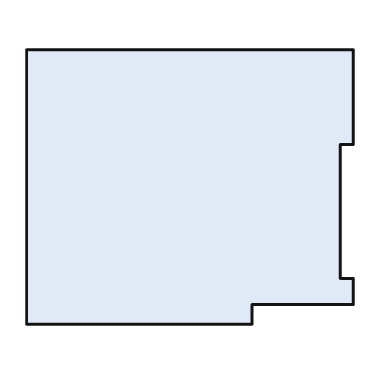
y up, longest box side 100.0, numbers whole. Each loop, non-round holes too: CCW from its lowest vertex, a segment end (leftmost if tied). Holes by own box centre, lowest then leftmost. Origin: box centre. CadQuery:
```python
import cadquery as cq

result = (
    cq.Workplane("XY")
    .moveTo(-50.0, -42.0)
    .lineTo(19.0, -42.0)
    .lineTo(19.0, -36.0)
    .lineTo(50.0, -36.0)
    .lineTo(50.0, -28.0)
    .lineTo(46.0, -28.0)
    .lineTo(46.0, 13.0)
    .lineTo(50.0, 13.0)
    .lineTo(50.0, 42.0)
    .lineTo(-50.0, 42.0)
    .close()
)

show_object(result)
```